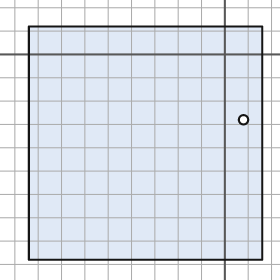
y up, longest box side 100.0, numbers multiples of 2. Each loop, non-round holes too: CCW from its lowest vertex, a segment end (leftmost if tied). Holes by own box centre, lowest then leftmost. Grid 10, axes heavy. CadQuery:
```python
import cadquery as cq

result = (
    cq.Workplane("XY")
    .moveTo(-84.0, -88.0)
    .lineTo(16.0, -88.0)
    .lineTo(16.0, 12.0)
    .lineTo(-84.0, 12.0)
    .close()
    .moveTo(8.0, -28.0)
    .circle(2.0)
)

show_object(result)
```